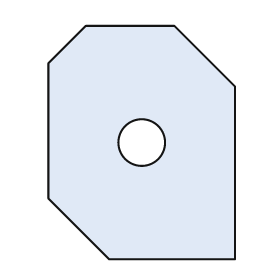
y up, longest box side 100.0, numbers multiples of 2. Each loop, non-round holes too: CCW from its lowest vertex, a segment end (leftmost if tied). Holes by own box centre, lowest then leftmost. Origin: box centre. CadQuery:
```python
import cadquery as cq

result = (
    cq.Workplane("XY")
    .moveTo(-14.0, -50.0)
    .lineTo(40.0, -50.0)
    .lineTo(40.0, 24.0)
    .lineTo(14.0, 50.0)
    .lineTo(-24.0, 50.0)
    .lineTo(-40.0, 34.0)
    .lineTo(-40.0, -24.0)
    .close()
    .moveTo(0.0, 0.0)
    .circle(10.0)
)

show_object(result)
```